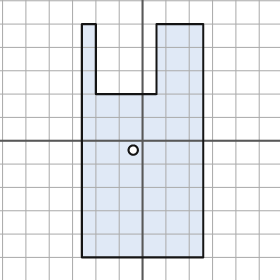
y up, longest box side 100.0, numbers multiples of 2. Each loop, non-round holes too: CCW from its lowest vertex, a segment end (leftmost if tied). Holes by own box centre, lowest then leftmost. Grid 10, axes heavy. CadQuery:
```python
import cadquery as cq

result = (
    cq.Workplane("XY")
    .moveTo(-26.0, -50.0)
    .lineTo(26.0, -50.0)
    .lineTo(26.0, 50.0)
    .lineTo(6.0, 50.0)
    .lineTo(6.0, 20.0)
    .lineTo(-20.0, 20.0)
    .lineTo(-20.0, 50.0)
    .lineTo(-26.0, 50.0)
    .close()
    .moveTo(-4.0, -4.0)
    .circle(2.0)
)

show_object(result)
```